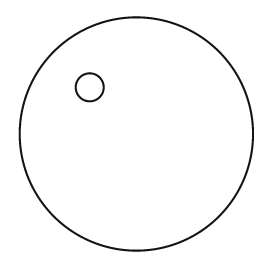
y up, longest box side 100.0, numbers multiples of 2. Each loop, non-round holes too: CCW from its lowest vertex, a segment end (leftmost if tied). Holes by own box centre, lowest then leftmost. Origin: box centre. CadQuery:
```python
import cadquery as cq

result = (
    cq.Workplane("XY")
    .moveTo(0.0, 0.0)
    .circle(50.0)
    .moveTo(-20.0, 20.0)
    .circle(6.0)
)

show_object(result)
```